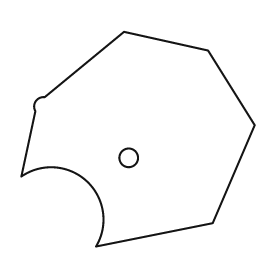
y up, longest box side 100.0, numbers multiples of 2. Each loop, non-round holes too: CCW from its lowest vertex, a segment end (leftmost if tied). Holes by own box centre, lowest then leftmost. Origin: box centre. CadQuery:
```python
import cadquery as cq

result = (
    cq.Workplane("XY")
    .moveTo(-18.0, -46.0)
    .lineTo(32.0, -36.0)
    .lineTo(50.0, 6.0)
    .lineTo(30.0, 38.0)
    .lineTo(-6.0, 46.0)
    .lineTo(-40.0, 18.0)
    .threePointArc((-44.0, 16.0), (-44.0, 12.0))
    .lineTo(-50.0, -16.0)
    .threePointArc((-22.0, -18.0), (-18.0, -46.0))
    .close()
    .moveTo(-4.0, -8.0)
    .circle(4.0)
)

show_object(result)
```